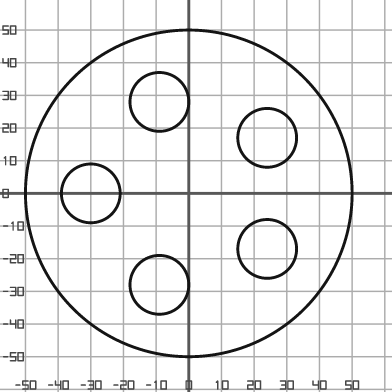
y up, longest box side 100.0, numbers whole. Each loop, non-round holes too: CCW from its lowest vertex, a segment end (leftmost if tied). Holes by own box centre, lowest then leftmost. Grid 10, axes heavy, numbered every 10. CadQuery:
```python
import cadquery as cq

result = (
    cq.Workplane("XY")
    .moveTo(0.0, 0.0)
    .circle(50.0)
    .moveTo(-9.0, -28.0)
    .circle(9.0)
    .moveTo(24.0, -17.0)
    .circle(9.0)
    .moveTo(-30.0, 0.0)
    .circle(9.0)
    .moveTo(24.0, 17.0)
    .circle(9.0)
    .moveTo(-9.0, 28.0)
    .circle(9.0)
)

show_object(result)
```